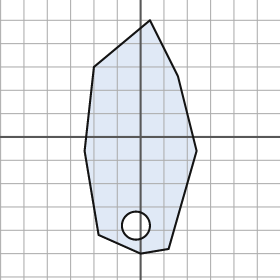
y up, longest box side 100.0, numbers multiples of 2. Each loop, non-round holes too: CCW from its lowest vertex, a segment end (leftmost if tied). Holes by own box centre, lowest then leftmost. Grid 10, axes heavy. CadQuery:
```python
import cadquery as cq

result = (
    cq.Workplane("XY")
    .moveTo(0.0, -50.0)
    .lineTo(12.0, -48.0)
    .lineTo(24.0, -6.0)
    .lineTo(16.0, 26.0)
    .lineTo(4.0, 50.0)
    .lineTo(-20.0, 30.0)
    .lineTo(-24.0, -6.0)
    .lineTo(-18.0, -42.0)
    .close()
    .moveTo(-2.0, -38.0)
    .circle(6.0)
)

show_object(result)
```